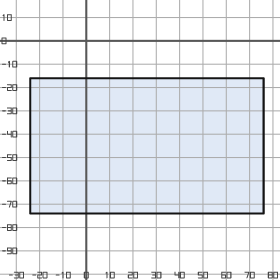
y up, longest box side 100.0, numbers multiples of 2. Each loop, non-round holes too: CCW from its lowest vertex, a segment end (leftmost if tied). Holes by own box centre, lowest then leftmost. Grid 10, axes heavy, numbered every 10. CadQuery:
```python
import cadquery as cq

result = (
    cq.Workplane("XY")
    .moveTo(-24.0, -74.0)
    .lineTo(76.0, -74.0)
    .lineTo(76.0, -16.0)
    .lineTo(-24.0, -16.0)
    .close()
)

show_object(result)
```